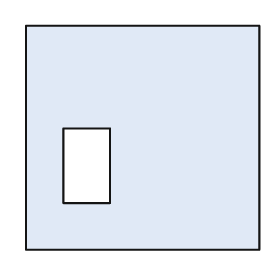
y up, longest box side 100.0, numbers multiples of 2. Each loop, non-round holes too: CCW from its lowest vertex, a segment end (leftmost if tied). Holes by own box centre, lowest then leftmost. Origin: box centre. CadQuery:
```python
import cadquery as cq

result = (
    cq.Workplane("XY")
    .moveTo(-50.0, -48.0)
    .lineTo(50.0, -48.0)
    .lineTo(50.0, 48.0)
    .lineTo(-50.0, 48.0)
    .close()
    .moveTo(-34.0, -28.0)
    .lineTo(-14.0, -28.0)
    .lineTo(-14.0, 4.0)
    .lineTo(-34.0, 4.0)
    .close()
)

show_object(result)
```